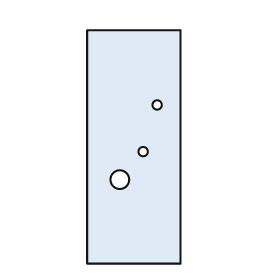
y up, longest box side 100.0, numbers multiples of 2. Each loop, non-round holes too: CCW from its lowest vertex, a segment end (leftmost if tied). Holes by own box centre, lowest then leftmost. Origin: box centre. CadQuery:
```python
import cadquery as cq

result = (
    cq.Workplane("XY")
    .moveTo(-20.0, -50.0)
    .lineTo(20.0, -50.0)
    .lineTo(20.0, 50.0)
    .lineTo(-20.0, 50.0)
    .close()
    .moveTo(-6.0, -14.0)
    .circle(4.0)
    .moveTo(4.0, -2.0)
    .circle(2.0)
    .moveTo(10.0, 18.0)
    .circle(2.0)
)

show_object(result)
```